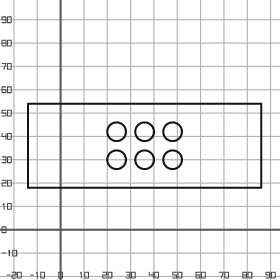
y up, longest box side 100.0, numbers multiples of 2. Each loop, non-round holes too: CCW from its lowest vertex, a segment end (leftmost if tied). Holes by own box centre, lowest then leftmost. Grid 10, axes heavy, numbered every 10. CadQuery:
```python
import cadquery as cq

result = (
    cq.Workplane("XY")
    .moveTo(-14.0, 18.0)
    .lineTo(86.0, 18.0)
    .lineTo(86.0, 54.0)
    .lineTo(-14.0, 54.0)
    .close()
    .moveTo(24.0, 30.0)
    .circle(4.0)
    .moveTo(36.0, 30.0)
    .circle(4.0)
    .moveTo(48.0, 30.0)
    .circle(4.0)
    .moveTo(24.0, 42.0)
    .circle(4.0)
    .moveTo(36.0, 42.0)
    .circle(4.0)
    .moveTo(48.0, 42.0)
    .circle(4.0)
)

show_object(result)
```